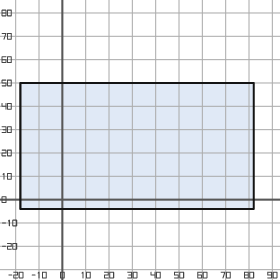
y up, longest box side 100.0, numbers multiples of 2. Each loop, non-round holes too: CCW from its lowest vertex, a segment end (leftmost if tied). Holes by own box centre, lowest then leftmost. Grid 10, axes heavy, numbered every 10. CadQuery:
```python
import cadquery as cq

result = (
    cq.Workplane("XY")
    .moveTo(-18.0, -4.0)
    .lineTo(82.0, -4.0)
    .lineTo(82.0, 50.0)
    .lineTo(-18.0, 50.0)
    .close()
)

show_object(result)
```